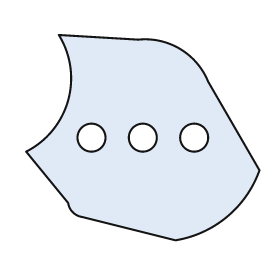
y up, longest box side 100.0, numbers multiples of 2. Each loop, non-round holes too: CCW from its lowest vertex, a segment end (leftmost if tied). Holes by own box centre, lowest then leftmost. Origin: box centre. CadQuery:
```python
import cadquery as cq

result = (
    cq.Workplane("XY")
    .moveTo(14.0, -44.0)
    .threePointArc((36.0, -34.0), (50.0, -14.0))
    .lineTo(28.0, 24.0)
    .threePointArc((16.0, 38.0), (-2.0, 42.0))
    .lineTo(-36.0, 44.0)
    .threePointArc((-32.0, 16.0), (-50.0, -6.0))
    .lineTo(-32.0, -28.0)
    .threePointArc((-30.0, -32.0), (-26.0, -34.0))
    .close()
    .moveTo(-22.0, 0.0)
    .circle(6.0)
    .moveTo(0.0, 0.0)
    .circle(6.0)
    .moveTo(22.0, 0.0)
    .circle(6.0)
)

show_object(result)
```